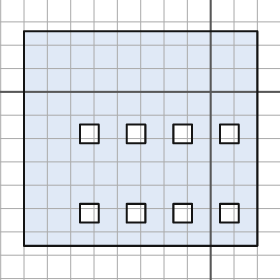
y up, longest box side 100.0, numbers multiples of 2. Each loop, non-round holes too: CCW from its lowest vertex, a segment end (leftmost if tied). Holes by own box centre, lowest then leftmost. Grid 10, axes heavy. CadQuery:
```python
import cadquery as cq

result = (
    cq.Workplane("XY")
    .moveTo(-80.0, -66.0)
    .lineTo(20.0, -66.0)
    .lineTo(20.0, 26.0)
    .lineTo(-80.0, 26.0)
    .close()
    .moveTo(-56.0, -56.0)
    .lineTo(-48.0, -56.0)
    .lineTo(-48.0, -48.0)
    .lineTo(-56.0, -48.0)
    .close()
    .moveTo(-36.0, -56.0)
    .lineTo(-28.0, -56.0)
    .lineTo(-28.0, -48.0)
    .lineTo(-36.0, -48.0)
    .close()
    .moveTo(-16.0, -56.0)
    .lineTo(-8.0, -56.0)
    .lineTo(-8.0, -48.0)
    .lineTo(-16.0, -48.0)
    .close()
    .moveTo(4.0, -56.0)
    .lineTo(12.0, -56.0)
    .lineTo(12.0, -48.0)
    .lineTo(4.0, -48.0)
    .close()
    .moveTo(-56.0, -22.0)
    .lineTo(-48.0, -22.0)
    .lineTo(-48.0, -14.0)
    .lineTo(-56.0, -14.0)
    .close()
    .moveTo(-36.0, -22.0)
    .lineTo(-28.0, -22.0)
    .lineTo(-28.0, -14.0)
    .lineTo(-36.0, -14.0)
    .close()
    .moveTo(-16.0, -22.0)
    .lineTo(-8.0, -22.0)
    .lineTo(-8.0, -14.0)
    .lineTo(-16.0, -14.0)
    .close()
    .moveTo(4.0, -22.0)
    .lineTo(12.0, -22.0)
    .lineTo(12.0, -14.0)
    .lineTo(4.0, -14.0)
    .close()
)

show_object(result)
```